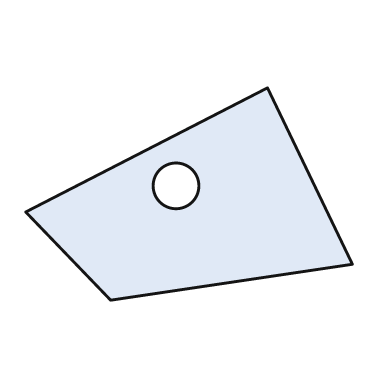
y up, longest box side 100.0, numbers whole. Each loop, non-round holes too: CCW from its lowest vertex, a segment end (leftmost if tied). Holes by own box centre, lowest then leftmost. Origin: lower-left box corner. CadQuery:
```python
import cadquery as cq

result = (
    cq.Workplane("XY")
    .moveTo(26.0, 0.0)
    .lineTo(100.0, 11.0)
    .lineTo(74.0, 65.0)
    .lineTo(0.0, 27.0)
    .close()
    .moveTo(46.0, 35.0)
    .circle(7.0)
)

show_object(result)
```